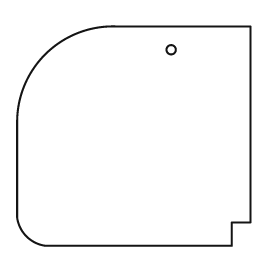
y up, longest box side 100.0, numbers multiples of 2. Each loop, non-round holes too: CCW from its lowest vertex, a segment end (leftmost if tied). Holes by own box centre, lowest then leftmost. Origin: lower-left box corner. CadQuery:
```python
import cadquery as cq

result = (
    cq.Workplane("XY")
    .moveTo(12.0, 0.0)
    .lineTo(92.0, 0.0)
    .lineTo(92.0, 10.0)
    .lineTo(100.0, 10.0)
    .lineTo(100.0, 94.0)
    .lineTo(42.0, 94.0)
    .threePointArc((12.0, 82.0), (0.0, 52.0))
    .lineTo(0.0, 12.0)
    .threePointArc((4.0, 4.0), (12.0, 0.0))
    .close()
    .moveTo(66.0, 84.0)
    .circle(2.0)
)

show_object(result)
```